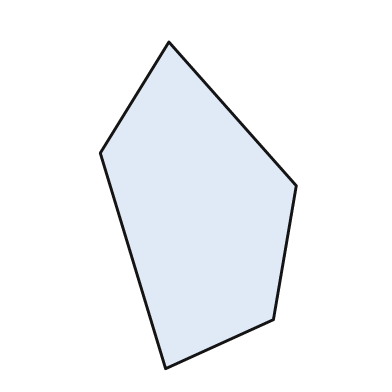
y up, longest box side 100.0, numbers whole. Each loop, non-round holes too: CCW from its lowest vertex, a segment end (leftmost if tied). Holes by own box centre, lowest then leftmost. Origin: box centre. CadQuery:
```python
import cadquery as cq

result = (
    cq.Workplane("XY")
    .moveTo(-10.0, -50.0)
    .lineTo(23.0, -35.0)
    .lineTo(30.0, 6.0)
    .lineTo(-9.0, 50.0)
    .lineTo(-30.0, 16.0)
    .close()
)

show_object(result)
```